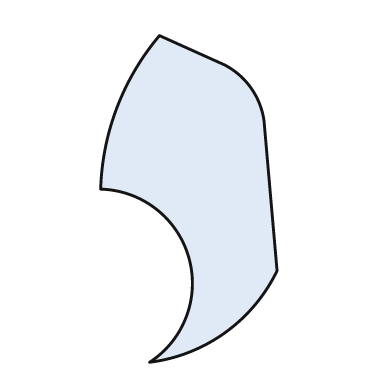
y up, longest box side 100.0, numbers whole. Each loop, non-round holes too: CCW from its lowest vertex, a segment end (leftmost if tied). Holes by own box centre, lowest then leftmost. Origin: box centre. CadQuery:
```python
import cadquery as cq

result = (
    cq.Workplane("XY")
    .moveTo(-12.0, -50.0)
    .threePointArc((11.0, -41.0), (27.0, -22.0))
    .lineTo(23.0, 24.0)
    .threePointArc((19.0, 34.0), (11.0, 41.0))
    .lineTo(-9.0, 50.0)
    .threePointArc((-22.0, 28.0), (-27.0, 3.0))
    .threePointArc((0.0, -18.0), (-12.0, -50.0))
    .close()
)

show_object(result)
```